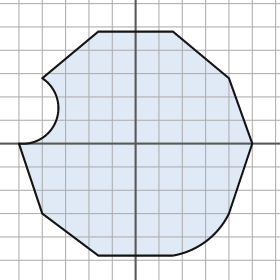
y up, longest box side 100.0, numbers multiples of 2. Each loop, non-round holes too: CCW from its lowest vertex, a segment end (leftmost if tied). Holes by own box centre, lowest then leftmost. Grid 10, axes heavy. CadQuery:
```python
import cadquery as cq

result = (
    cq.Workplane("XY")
    .moveTo(-16.0, -48.0)
    .lineTo(16.0, -48.0)
    .threePointArc((30.0, -42.0), (40.0, -30.0))
    .lineTo(50.0, 0.0)
    .lineTo(40.0, 28.0)
    .lineTo(16.0, 48.0)
    .lineTo(-16.0, 48.0)
    .lineTo(-40.0, 28.0)
    .threePointArc((-34.0, 10.0), (-50.0, 0.0))
    .lineTo(-40.0, -30.0)
    .close()
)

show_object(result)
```